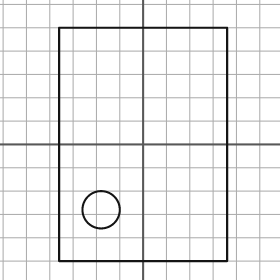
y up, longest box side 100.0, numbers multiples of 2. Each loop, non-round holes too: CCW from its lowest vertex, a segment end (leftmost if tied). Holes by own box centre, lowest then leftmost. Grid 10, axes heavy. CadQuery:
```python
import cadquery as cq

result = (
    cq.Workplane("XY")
    .moveTo(-36.0, -50.0)
    .lineTo(36.0, -50.0)
    .lineTo(36.0, 50.0)
    .lineTo(-36.0, 50.0)
    .close()
    .moveTo(-18.0, -28.0)
    .circle(8.0)
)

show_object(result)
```